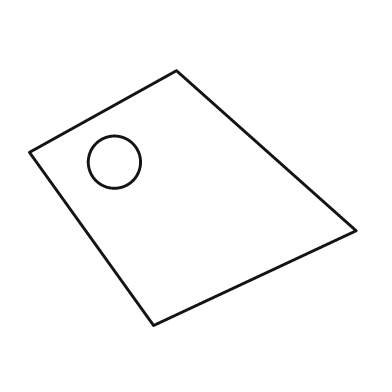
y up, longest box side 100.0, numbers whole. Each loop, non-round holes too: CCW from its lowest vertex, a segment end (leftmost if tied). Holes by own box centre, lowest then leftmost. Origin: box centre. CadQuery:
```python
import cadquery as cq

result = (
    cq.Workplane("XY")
    .moveTo(-12.0, -39.0)
    .lineTo(50.0, -10.0)
    .lineTo(-5.0, 39.0)
    .lineTo(-50.0, 14.0)
    .close()
    .moveTo(-24.0, 11.0)
    .circle(8.0)
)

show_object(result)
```